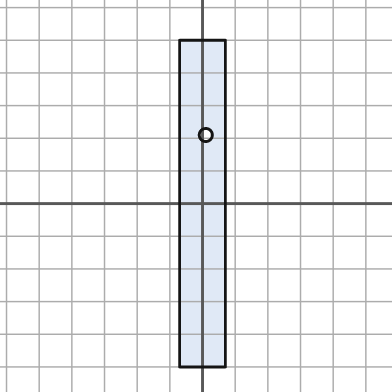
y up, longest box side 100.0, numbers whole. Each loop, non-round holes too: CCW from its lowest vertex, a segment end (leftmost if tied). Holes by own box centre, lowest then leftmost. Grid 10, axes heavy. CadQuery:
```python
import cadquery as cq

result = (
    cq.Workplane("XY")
    .moveTo(-7.0, -50.0)
    .lineTo(7.0, -50.0)
    .lineTo(7.0, 50.0)
    .lineTo(-7.0, 50.0)
    .close()
    .moveTo(1.0, 21.0)
    .circle(2.0)
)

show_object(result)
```